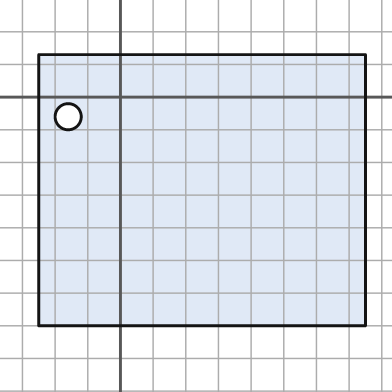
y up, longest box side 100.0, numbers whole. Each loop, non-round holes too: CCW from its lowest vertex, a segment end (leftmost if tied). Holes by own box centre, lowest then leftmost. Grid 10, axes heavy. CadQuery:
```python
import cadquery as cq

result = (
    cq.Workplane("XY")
    .moveTo(-25.0, -70.0)
    .lineTo(75.0, -70.0)
    .lineTo(75.0, 13.0)
    .lineTo(-25.0, 13.0)
    .close()
    .moveTo(-16.0, -6.0)
    .circle(4.0)
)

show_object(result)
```